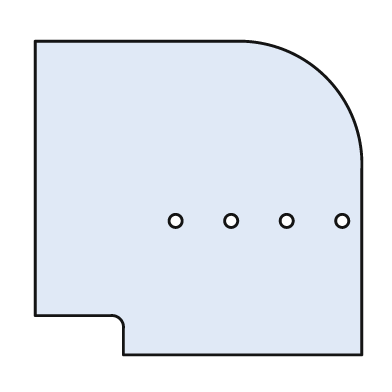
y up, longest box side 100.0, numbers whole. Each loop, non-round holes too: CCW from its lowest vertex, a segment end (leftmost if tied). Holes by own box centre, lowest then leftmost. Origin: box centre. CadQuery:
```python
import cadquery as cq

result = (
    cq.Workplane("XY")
    .moveTo(-23.0, -48.0)
    .lineTo(50.0, -48.0)
    .lineTo(50.0, 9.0)
    .threePointArc((39.0, 37.0), (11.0, 48.0))
    .lineTo(-50.0, 48.0)
    .lineTo(-50.0, -36.0)
    .lineTo(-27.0, -36.0)
    .threePointArc((-24.0, -37.0), (-23.0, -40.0))
    .close()
    .moveTo(-7.0, -7.0)
    .circle(2.0)
    .moveTo(10.0, -7.0)
    .circle(2.0)
    .moveTo(27.0, -7.0)
    .circle(2.0)
    .moveTo(44.0, -7.0)
    .circle(2.0)
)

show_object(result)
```